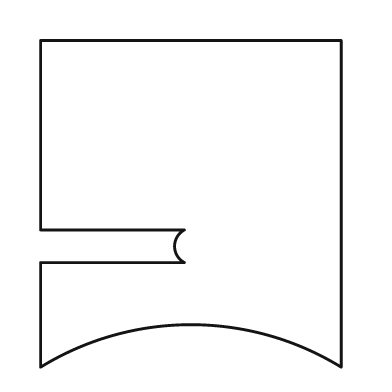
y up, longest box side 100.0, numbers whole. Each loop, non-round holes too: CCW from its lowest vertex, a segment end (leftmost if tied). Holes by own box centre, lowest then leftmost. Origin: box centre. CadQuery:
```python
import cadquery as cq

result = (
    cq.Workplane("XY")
    .moveTo(-46.0, -50.0)
    .threePointArc((0.0, -37.0), (46.0, -50.0))
    .lineTo(46.0, 50.0)
    .lineTo(-46.0, 50.0)
    .lineTo(-46.0, -8.0)
    .lineTo(-2.0, -8.0)
    .threePointArc((-5.0, -13.0), (-2.0, -18.0))
    .lineTo(-46.0, -18.0)
    .close()
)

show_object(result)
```